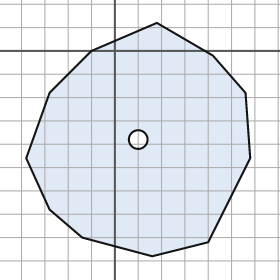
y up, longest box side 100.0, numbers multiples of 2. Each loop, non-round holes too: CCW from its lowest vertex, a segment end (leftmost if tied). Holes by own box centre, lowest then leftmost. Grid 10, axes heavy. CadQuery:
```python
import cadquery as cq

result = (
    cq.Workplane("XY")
    .moveTo(16.0, -88.0)
    .lineTo(40.0, -82.0)
    .lineTo(58.0, -46.0)
    .lineTo(56.0, -18.0)
    .lineTo(42.0, -2.0)
    .lineTo(18.0, 12.0)
    .lineTo(-10.0, 0.0)
    .lineTo(-28.0, -18.0)
    .lineTo(-38.0, -46.0)
    .lineTo(-28.0, -68.0)
    .lineTo(-14.0, -80.0)
    .close()
    .moveTo(10.0, -38.0)
    .circle(4.0)
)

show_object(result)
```